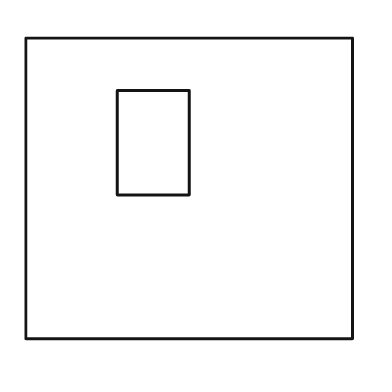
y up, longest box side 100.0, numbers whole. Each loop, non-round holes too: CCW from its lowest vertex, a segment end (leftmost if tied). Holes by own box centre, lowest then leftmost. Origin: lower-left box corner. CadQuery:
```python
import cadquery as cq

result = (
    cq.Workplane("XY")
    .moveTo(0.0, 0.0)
    .lineTo(100.0, 0.0)
    .lineTo(100.0, 92.0)
    .lineTo(0.0, 92.0)
    .close()
    .moveTo(28.0, 44.0)
    .lineTo(50.0, 44.0)
    .lineTo(50.0, 76.0)
    .lineTo(28.0, 76.0)
    .close()
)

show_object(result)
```